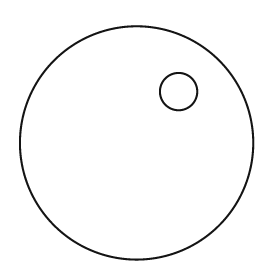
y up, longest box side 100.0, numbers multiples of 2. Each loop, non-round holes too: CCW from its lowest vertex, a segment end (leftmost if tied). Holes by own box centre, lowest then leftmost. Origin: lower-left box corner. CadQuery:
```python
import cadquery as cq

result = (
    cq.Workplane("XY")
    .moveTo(50.0, 50.0)
    .circle(50.0)
    .moveTo(68.0, 72.0)
    .circle(8.0)
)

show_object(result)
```